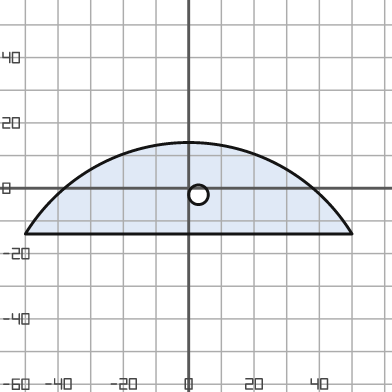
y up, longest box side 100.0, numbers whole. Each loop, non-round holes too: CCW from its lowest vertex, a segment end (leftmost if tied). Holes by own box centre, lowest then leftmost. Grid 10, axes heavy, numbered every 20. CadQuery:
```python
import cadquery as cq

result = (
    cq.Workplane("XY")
    .moveTo(-50.0, -14.0)
    .lineTo(50.0, -14.0)
    .threePointArc((0.0, 14.0), (-50.0, -14.0))
    .close()
    .moveTo(3.0, -2.0)
    .circle(3.0)
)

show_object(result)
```